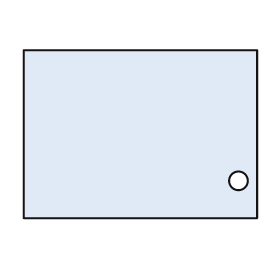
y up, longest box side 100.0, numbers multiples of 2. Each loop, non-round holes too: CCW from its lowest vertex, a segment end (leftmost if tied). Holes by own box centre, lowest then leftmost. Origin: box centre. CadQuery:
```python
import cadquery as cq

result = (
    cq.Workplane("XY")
    .moveTo(-50.0, -36.0)
    .lineTo(50.0, -36.0)
    .lineTo(50.0, 36.0)
    .lineTo(-50.0, 36.0)
    .close()
    .moveTo(42.0, -20.0)
    .circle(4.0)
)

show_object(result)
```